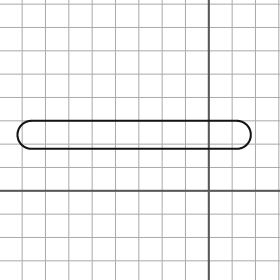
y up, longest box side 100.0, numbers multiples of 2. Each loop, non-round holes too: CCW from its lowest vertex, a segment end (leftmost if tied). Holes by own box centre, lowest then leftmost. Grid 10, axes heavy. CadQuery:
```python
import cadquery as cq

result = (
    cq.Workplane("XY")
    .moveTo(-76.0, 18.0)
    .lineTo(12.0, 18.0)
    .threePointArc((18.0, 24.0), (12.0, 30.0))
    .lineTo(-76.0, 30.0)
    .threePointArc((-82.0, 24.0), (-76.0, 18.0))
    .close()
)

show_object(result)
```